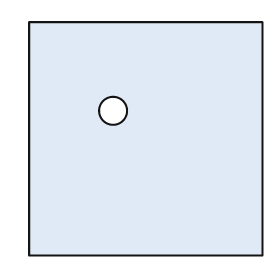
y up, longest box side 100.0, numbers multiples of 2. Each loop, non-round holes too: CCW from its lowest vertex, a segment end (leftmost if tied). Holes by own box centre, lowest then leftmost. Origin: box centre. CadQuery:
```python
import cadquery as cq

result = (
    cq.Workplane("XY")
    .moveTo(-50.0, -50.0)
    .lineTo(50.0, -50.0)
    .lineTo(50.0, 50.0)
    .lineTo(-50.0, 50.0)
    .close()
    .moveTo(-14.0, 12.0)
    .circle(6.0)
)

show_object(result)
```